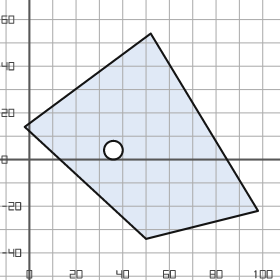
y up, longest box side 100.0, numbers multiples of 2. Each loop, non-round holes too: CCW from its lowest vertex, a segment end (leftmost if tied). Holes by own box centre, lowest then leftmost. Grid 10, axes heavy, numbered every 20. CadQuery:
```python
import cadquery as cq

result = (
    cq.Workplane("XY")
    .moveTo(50.0, -34.0)
    .lineTo(98.0, -22.0)
    .lineTo(52.0, 54.0)
    .lineTo(-2.0, 14.0)
    .close()
    .moveTo(36.0, 4.0)
    .circle(4.0)
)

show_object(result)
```